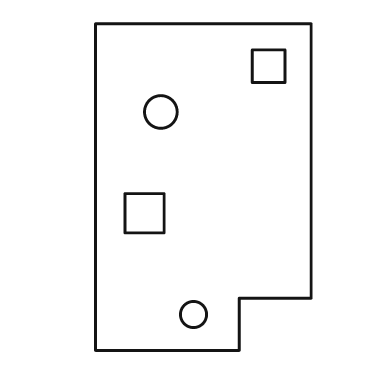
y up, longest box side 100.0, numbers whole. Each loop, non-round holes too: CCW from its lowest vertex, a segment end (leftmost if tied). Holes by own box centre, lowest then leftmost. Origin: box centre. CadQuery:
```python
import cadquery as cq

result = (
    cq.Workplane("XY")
    .moveTo(-33.0, -50.0)
    .lineTo(11.0, -50.0)
    .lineTo(11.0, -34.0)
    .lineTo(33.0, -34.0)
    .lineTo(33.0, 50.0)
    .lineTo(-33.0, 50.0)
    .close()
    .moveTo(-3.0, -39.0)
    .circle(4.0)
    .moveTo(-24.0, -14.0)
    .lineTo(-12.0, -14.0)
    .lineTo(-12.0, -2.0)
    .lineTo(-24.0, -2.0)
    .close()
    .moveTo(-13.0, 23.0)
    .circle(5.0)
    .moveTo(15.0, 32.0)
    .lineTo(25.0, 32.0)
    .lineTo(25.0, 42.0)
    .lineTo(15.0, 42.0)
    .close()
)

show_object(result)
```